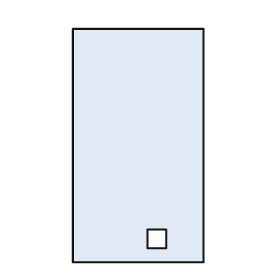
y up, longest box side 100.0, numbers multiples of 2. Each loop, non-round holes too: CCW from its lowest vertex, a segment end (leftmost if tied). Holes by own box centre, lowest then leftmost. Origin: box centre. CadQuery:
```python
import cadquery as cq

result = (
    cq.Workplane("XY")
    .moveTo(-28.0, -50.0)
    .lineTo(28.0, -50.0)
    .lineTo(28.0, 50.0)
    .lineTo(-28.0, 50.0)
    .close()
    .moveTo(4.0, -44.0)
    .lineTo(12.0, -44.0)
    .lineTo(12.0, -36.0)
    .lineTo(4.0, -36.0)
    .close()
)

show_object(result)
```